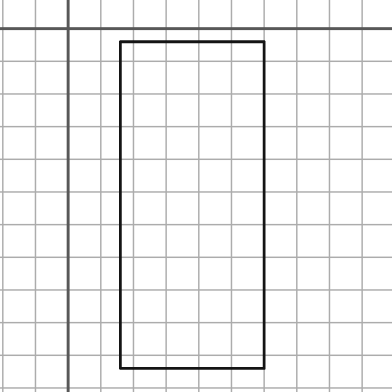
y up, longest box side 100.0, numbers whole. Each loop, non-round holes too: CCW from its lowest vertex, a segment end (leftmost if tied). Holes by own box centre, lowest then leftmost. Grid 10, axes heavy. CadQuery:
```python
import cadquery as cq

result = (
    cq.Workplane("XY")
    .moveTo(16.0, -104.0)
    .lineTo(60.0, -104.0)
    .lineTo(60.0, -4.0)
    .lineTo(16.0, -4.0)
    .close()
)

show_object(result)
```